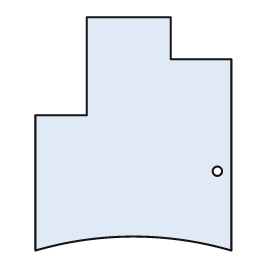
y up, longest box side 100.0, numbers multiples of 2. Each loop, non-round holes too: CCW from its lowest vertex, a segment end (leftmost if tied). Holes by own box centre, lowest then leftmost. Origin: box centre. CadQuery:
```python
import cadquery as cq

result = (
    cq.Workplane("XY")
    .moveTo(-42.0, -50.0)
    .threePointArc((0.0, -44.0), (42.0, -50.0))
    .lineTo(42.0, 32.0)
    .lineTo(16.0, 32.0)
    .lineTo(16.0, 50.0)
    .lineTo(-20.0, 50.0)
    .lineTo(-20.0, 8.0)
    .lineTo(-42.0, 8.0)
    .close()
    .moveTo(36.0, -16.0)
    .circle(2.0)
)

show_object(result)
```